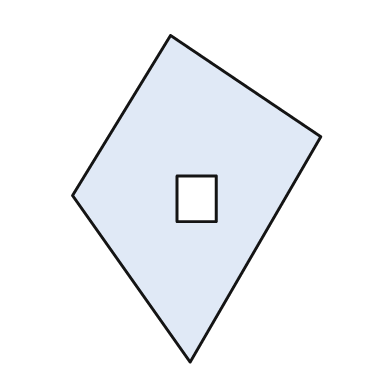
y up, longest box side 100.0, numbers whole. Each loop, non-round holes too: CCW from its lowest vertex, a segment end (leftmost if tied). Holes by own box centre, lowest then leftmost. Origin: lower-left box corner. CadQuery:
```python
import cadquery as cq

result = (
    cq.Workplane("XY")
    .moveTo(36.0, 0.0)
    .lineTo(76.0, 69.0)
    .lineTo(30.0, 100.0)
    .lineTo(0.0, 51.0)
    .close()
    .moveTo(32.0, 43.0)
    .lineTo(44.0, 43.0)
    .lineTo(44.0, 57.0)
    .lineTo(32.0, 57.0)
    .close()
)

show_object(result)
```